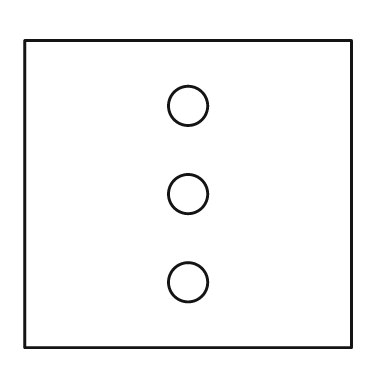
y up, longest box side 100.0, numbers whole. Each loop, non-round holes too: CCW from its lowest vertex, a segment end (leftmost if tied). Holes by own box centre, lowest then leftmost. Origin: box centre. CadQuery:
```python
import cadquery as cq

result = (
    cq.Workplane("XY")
    .moveTo(-50.0, -47.0)
    .lineTo(50.0, -47.0)
    .lineTo(50.0, 47.0)
    .lineTo(-50.0, 47.0)
    .close()
    .moveTo(0.0, -27.0)
    .circle(6.0)
    .moveTo(0.0, 0.0)
    .circle(6.0)
    .moveTo(0.0, 27.0)
    .circle(6.0)
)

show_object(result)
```